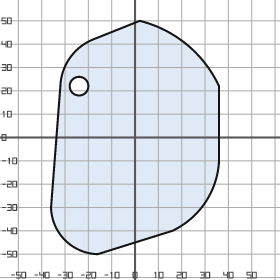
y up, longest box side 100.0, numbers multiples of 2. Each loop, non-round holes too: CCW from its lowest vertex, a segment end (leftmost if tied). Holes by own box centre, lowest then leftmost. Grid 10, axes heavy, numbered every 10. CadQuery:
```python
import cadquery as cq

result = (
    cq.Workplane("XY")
    .moveTo(-16.0, -50.0)
    .lineTo(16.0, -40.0)
    .threePointArc((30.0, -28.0), (36.0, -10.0))
    .lineTo(36.0, 22.0)
    .threePointArc((22.0, 40.0), (2.0, 50.0))
    .lineTo(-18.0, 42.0)
    .threePointArc((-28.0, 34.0), (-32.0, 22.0))
    .lineTo(-36.0, -30.0)
    .threePointArc((-30.0, -44.0), (-16.0, -50.0))
    .close()
    .moveTo(-24.0, 22.0)
    .circle(4.0)
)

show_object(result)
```